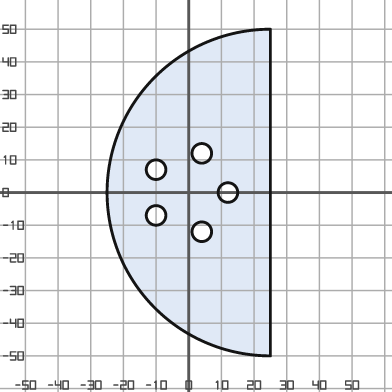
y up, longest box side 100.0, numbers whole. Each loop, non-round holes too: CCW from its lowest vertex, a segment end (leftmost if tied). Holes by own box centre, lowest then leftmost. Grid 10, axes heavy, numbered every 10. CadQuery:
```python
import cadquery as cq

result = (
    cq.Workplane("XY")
    .moveTo(25.0, -50.0)
    .lineTo(25.0, 50.0)
    .threePointArc((-25.0, 0.0), (25.0, -50.0))
    .close()
    .moveTo(4.0, -12.0)
    .circle(3.0)
    .moveTo(-10.0, -7.0)
    .circle(3.0)
    .moveTo(12.0, 0.0)
    .circle(3.0)
    .moveTo(-10.0, 7.0)
    .circle(3.0)
    .moveTo(4.0, 12.0)
    .circle(3.0)
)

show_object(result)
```